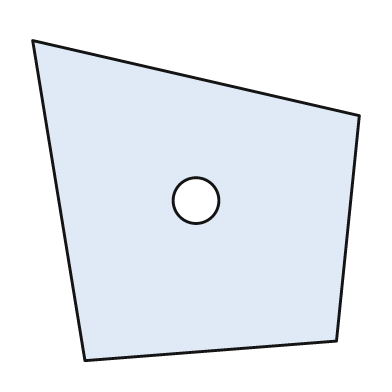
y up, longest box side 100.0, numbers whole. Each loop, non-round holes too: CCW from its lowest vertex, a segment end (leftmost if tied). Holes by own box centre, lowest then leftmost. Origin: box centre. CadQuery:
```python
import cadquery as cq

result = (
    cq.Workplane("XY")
    .moveTo(-34.0, -49.0)
    .lineTo(43.0, -43.0)
    .lineTo(50.0, 26.0)
    .lineTo(-50.0, 49.0)
    .close()
    .moveTo(0.0, 0.0)
    .circle(7.0)
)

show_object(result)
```